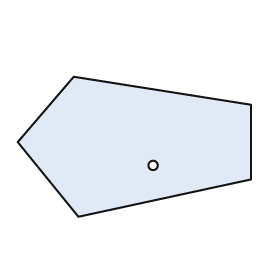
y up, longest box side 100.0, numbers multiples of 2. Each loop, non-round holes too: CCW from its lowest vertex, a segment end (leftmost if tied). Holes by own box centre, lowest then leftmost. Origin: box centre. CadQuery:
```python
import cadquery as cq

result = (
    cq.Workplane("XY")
    .moveTo(-24.0, -30.0)
    .lineTo(50.0, -14.0)
    .lineTo(50.0, 18.0)
    .lineTo(-26.0, 30.0)
    .lineTo(-50.0, 2.0)
    .close()
    .moveTo(8.0, -8.0)
    .circle(2.0)
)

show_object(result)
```